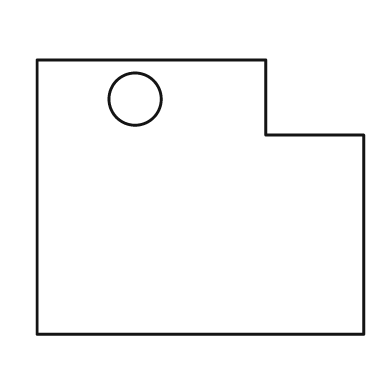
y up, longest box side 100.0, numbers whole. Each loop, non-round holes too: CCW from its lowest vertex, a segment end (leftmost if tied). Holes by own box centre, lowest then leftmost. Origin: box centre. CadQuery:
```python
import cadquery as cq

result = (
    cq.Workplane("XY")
    .moveTo(-50.0, -42.0)
    .lineTo(50.0, -42.0)
    .lineTo(50.0, 19.0)
    .lineTo(20.0, 19.0)
    .lineTo(20.0, 42.0)
    .lineTo(-50.0, 42.0)
    .close()
    .moveTo(-20.0, 30.0)
    .circle(8.0)
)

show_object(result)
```